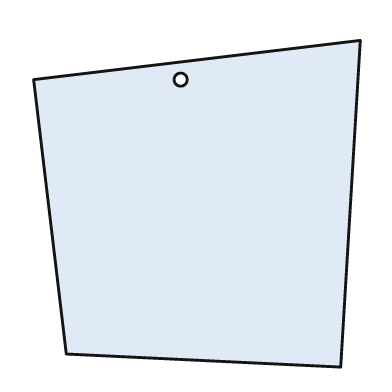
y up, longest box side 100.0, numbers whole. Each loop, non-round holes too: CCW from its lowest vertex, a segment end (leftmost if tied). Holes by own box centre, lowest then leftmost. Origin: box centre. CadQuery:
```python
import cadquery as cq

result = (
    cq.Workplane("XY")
    .moveTo(44.0, -50.0)
    .lineTo(50.0, 50.0)
    .lineTo(-50.0, 38.0)
    .lineTo(-40.0, -46.0)
    .close()
    .moveTo(-5.0, 38.0)
    .circle(2.0)
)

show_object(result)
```